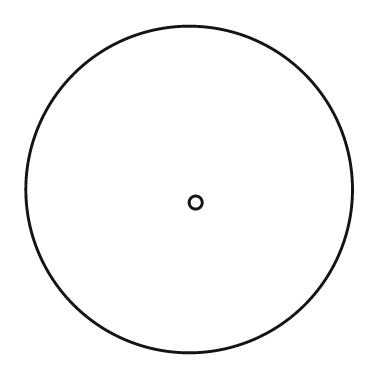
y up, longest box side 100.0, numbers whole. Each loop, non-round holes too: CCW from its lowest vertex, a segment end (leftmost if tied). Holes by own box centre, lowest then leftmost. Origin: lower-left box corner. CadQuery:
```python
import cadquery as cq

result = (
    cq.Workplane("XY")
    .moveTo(50.0, 50.0)
    .circle(50.0)
    .moveTo(52.0, 46.0)
    .circle(2.0)
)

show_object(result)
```